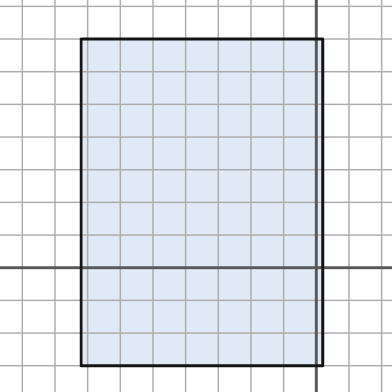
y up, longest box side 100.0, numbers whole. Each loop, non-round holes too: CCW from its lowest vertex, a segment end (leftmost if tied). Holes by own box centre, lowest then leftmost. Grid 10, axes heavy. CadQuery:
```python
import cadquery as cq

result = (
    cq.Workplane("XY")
    .moveTo(-72.0, -30.0)
    .lineTo(2.0, -30.0)
    .lineTo(2.0, 70.0)
    .lineTo(-72.0, 70.0)
    .close()
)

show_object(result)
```